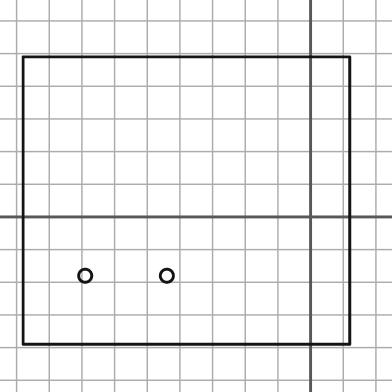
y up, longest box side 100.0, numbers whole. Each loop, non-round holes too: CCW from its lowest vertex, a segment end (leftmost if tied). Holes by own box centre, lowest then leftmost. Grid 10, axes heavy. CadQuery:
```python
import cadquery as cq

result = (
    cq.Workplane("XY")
    .moveTo(-88.0, -39.0)
    .lineTo(12.0, -39.0)
    .lineTo(12.0, 49.0)
    .lineTo(-88.0, 49.0)
    .close()
    .moveTo(-69.0, -18.0)
    .circle(2.0)
    .moveTo(-44.0, -18.0)
    .circle(2.0)
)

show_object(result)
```